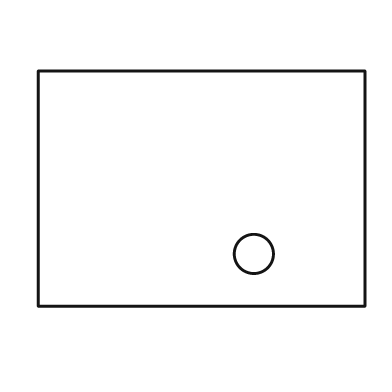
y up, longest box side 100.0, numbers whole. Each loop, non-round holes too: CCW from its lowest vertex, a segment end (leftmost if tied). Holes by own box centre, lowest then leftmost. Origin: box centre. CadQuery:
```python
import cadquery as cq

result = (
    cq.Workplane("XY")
    .moveTo(-50.0, -36.0)
    .lineTo(50.0, -36.0)
    .lineTo(50.0, 36.0)
    .lineTo(-50.0, 36.0)
    .close()
    .moveTo(16.0, -20.0)
    .circle(6.0)
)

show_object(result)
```